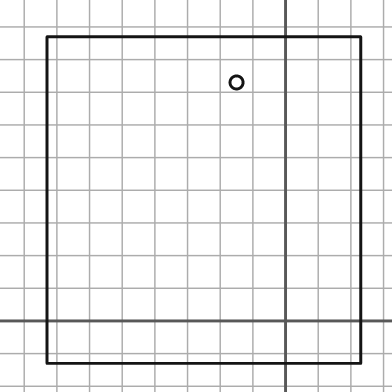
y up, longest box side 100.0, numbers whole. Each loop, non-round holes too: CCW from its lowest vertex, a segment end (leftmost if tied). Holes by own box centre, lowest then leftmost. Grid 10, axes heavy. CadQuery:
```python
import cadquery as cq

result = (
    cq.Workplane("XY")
    .moveTo(-73.0, -13.0)
    .lineTo(23.0, -13.0)
    .lineTo(23.0, 87.0)
    .lineTo(-73.0, 87.0)
    .close()
    .moveTo(-15.0, 73.0)
    .circle(2.0)
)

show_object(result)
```